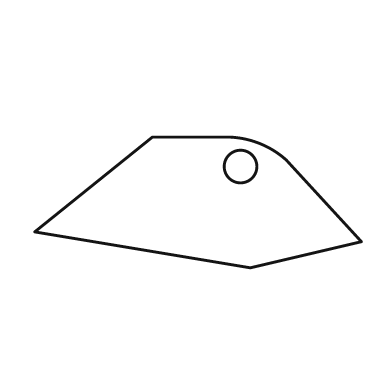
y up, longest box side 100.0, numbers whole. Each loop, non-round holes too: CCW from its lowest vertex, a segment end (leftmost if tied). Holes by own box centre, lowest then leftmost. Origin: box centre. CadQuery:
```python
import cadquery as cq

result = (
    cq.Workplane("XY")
    .moveTo(16.0, -20.0)
    .lineTo(50.0, -12.0)
    .lineTo(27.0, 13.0)
    .threePointArc((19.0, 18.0), (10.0, 20.0))
    .lineTo(-14.0, 20.0)
    .lineTo(-50.0, -9.0)
    .close()
    .moveTo(13.0, 11.0)
    .circle(5.0)
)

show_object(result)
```